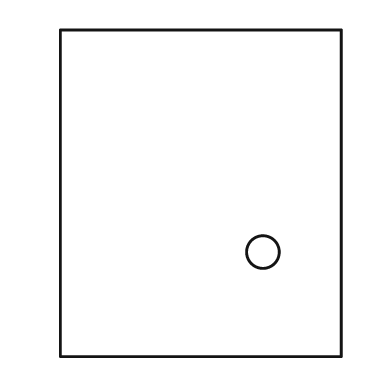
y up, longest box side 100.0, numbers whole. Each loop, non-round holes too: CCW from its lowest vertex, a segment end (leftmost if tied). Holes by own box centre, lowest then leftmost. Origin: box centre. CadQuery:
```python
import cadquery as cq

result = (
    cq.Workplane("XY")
    .moveTo(-43.0, -50.0)
    .lineTo(43.0, -50.0)
    .lineTo(43.0, 50.0)
    .lineTo(-43.0, 50.0)
    .close()
    .moveTo(19.0, -18.0)
    .circle(5.0)
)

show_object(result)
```